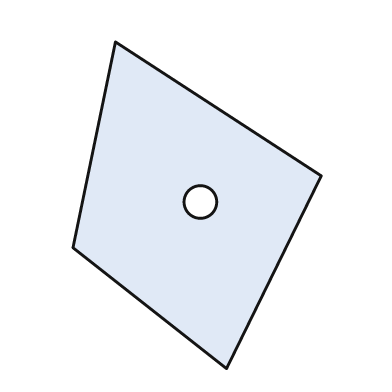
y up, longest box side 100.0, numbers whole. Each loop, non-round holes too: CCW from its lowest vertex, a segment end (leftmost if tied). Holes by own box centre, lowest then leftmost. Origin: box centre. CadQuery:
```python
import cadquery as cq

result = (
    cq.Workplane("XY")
    .moveTo(9.0, -50.0)
    .lineTo(38.0, 9.0)
    .lineTo(-25.0, 50.0)
    .lineTo(-38.0, -13.0)
    .close()
    .moveTo(1.0, 1.0)
    .circle(5.0)
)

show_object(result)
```